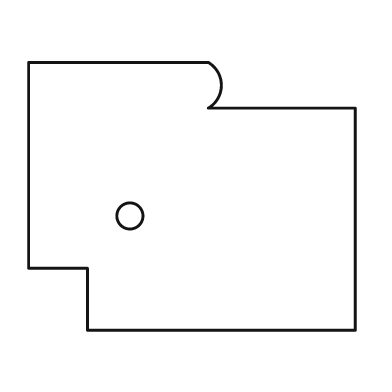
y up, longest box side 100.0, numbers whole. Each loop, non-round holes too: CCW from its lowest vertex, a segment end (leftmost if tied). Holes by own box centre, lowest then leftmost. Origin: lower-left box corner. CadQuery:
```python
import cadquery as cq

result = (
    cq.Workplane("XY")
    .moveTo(18.0, 0.0)
    .lineTo(100.0, 0.0)
    .lineTo(100.0, 68.0)
    .lineTo(55.0, 68.0)
    .threePointArc((59.0, 75.0), (55.0, 82.0))
    .lineTo(0.0, 82.0)
    .lineTo(0.0, 19.0)
    .lineTo(18.0, 19.0)
    .close()
    .moveTo(31.0, 35.0)
    .circle(4.0)
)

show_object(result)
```